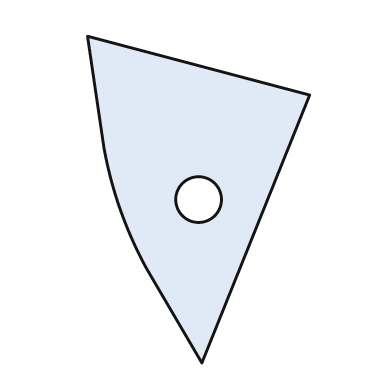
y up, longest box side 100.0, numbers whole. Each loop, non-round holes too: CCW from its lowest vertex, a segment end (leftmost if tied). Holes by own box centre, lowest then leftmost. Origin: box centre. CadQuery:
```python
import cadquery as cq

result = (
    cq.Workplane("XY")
    .moveTo(1.0, -50.0)
    .lineTo(34.0, 32.0)
    .lineTo(-34.0, 50.0)
    .lineTo(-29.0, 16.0)
    .threePointArc((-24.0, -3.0), (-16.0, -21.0))
    .close()
    .moveTo(0.0, 0.0)
    .circle(7.0)
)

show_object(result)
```